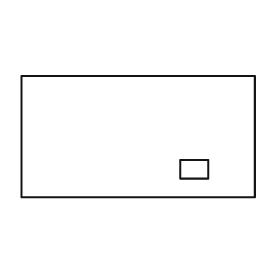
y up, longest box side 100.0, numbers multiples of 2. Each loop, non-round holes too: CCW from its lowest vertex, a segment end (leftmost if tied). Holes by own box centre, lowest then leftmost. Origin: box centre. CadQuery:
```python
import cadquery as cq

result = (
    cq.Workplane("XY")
    .moveTo(-50.0, -26.0)
    .lineTo(50.0, -26.0)
    .lineTo(50.0, 26.0)
    .lineTo(-50.0, 26.0)
    .close()
    .moveTo(18.0, -18.0)
    .lineTo(30.0, -18.0)
    .lineTo(30.0, -10.0)
    .lineTo(18.0, -10.0)
    .close()
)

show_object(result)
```